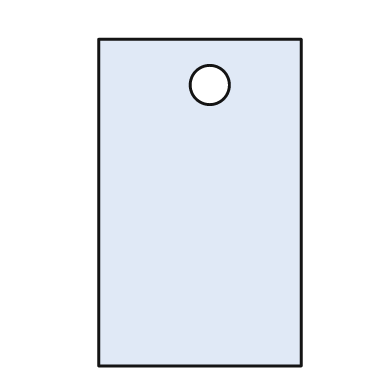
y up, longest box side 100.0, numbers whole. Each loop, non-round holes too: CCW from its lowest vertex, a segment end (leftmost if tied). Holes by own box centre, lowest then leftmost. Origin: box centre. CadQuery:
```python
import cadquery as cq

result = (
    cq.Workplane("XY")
    .moveTo(-31.0, -50.0)
    .lineTo(31.0, -50.0)
    .lineTo(31.0, 50.0)
    .lineTo(-31.0, 50.0)
    .close()
    .moveTo(3.0, 36.0)
    .circle(6.0)
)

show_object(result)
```